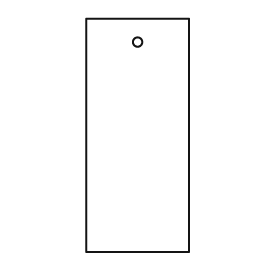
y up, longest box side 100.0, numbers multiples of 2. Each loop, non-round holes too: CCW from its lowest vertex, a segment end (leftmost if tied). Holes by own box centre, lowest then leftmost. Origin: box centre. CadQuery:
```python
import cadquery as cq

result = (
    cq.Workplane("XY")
    .moveTo(-22.0, -50.0)
    .lineTo(22.0, -50.0)
    .lineTo(22.0, 50.0)
    .lineTo(-22.0, 50.0)
    .close()
    .moveTo(0.0, 40.0)
    .circle(2.0)
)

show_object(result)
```